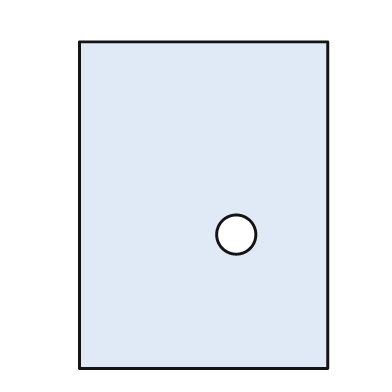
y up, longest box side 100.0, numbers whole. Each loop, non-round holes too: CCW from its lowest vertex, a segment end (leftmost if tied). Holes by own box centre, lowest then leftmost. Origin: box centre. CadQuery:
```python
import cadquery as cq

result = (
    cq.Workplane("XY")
    .moveTo(-38.0, -50.0)
    .lineTo(38.0, -50.0)
    .lineTo(38.0, 50.0)
    .lineTo(-38.0, 50.0)
    .close()
    .moveTo(10.0, -9.0)
    .circle(6.0)
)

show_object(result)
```